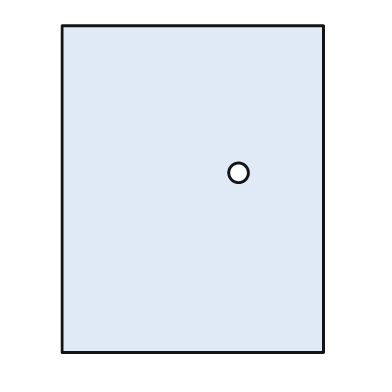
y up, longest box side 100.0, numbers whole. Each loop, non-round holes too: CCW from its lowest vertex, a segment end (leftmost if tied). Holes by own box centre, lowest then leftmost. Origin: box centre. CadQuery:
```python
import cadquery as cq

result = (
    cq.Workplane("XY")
    .moveTo(-40.0, -50.0)
    .lineTo(40.0, -50.0)
    .lineTo(40.0, 50.0)
    .lineTo(-40.0, 50.0)
    .close()
    .moveTo(14.0, 5.0)
    .circle(3.0)
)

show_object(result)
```